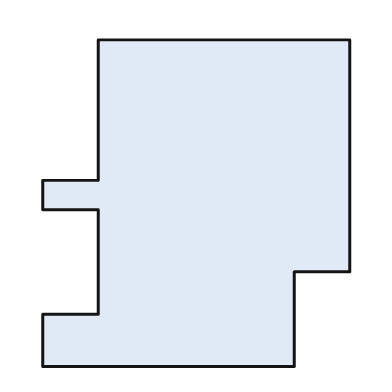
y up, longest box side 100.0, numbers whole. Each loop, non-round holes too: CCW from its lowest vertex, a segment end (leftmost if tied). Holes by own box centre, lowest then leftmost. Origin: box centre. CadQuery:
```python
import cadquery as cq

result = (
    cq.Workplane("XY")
    .moveTo(-47.0, -50.0)
    .lineTo(30.0, -50.0)
    .lineTo(30.0, -21.0)
    .lineTo(47.0, -21.0)
    .lineTo(47.0, 50.0)
    .lineTo(-30.0, 50.0)
    .lineTo(-30.0, 7.0)
    .lineTo(-47.0, 7.0)
    .lineTo(-47.0, -2.0)
    .lineTo(-30.0, -2.0)
    .lineTo(-30.0, -34.0)
    .lineTo(-47.0, -34.0)
    .close()
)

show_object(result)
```